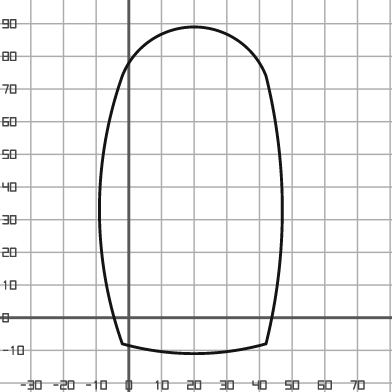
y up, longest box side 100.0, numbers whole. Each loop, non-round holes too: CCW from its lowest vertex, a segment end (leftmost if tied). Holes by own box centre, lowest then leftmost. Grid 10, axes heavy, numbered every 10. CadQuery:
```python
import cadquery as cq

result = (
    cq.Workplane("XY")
    .moveTo(-2.0, -8.0)
    .threePointArc((20.0, -11.0), (42.0, -8.0))
    .threePointArc((47.0, 33.0), (42.0, 74.0))
    .threePointArc((20.0, 89.0), (-2.0, 74.0))
    .threePointArc((-9.0, 33.0), (-2.0, -8.0))
    .close()
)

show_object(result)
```